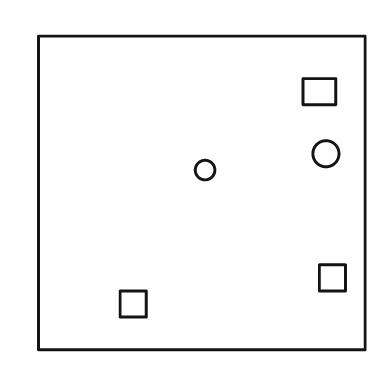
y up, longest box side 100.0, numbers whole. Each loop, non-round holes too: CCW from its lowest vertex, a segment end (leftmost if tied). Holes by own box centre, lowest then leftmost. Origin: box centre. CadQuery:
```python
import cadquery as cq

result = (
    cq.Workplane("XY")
    .moveTo(-50.0, -48.0)
    .lineTo(50.0, -48.0)
    .lineTo(50.0, 48.0)
    .lineTo(-50.0, 48.0)
    .close()
    .moveTo(-25.0, -38.0)
    .lineTo(-17.0, -38.0)
    .lineTo(-17.0, -30.0)
    .lineTo(-25.0, -30.0)
    .close()
    .moveTo(36.0, -30.0)
    .lineTo(44.0, -30.0)
    .lineTo(44.0, -22.0)
    .lineTo(36.0, -22.0)
    .close()
    .moveTo(1.0, 7.0)
    .circle(3.0)
    .moveTo(38.0, 12.0)
    .circle(4.0)
    .moveTo(31.0, 27.0)
    .lineTo(41.0, 27.0)
    .lineTo(41.0, 35.0)
    .lineTo(31.0, 35.0)
    .close()
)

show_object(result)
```